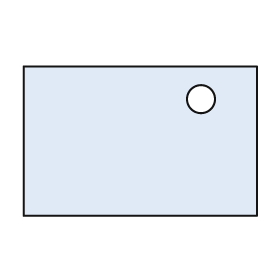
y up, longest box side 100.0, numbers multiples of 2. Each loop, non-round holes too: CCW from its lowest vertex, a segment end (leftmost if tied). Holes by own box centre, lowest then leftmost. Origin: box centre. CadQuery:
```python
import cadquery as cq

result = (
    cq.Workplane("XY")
    .moveTo(-50.0, -32.0)
    .lineTo(50.0, -32.0)
    .lineTo(50.0, 32.0)
    .lineTo(-50.0, 32.0)
    .close()
    .moveTo(26.0, 18.0)
    .circle(6.0)
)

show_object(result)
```